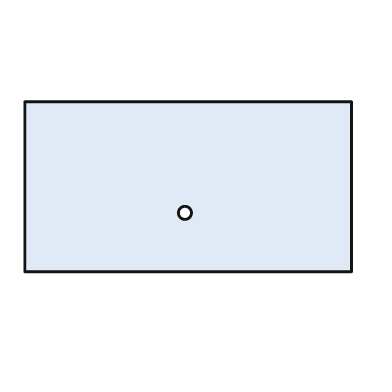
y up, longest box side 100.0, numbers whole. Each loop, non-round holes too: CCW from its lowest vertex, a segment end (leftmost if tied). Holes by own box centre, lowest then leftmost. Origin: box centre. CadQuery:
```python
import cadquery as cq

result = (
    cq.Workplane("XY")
    .moveTo(-50.0, -26.0)
    .lineTo(50.0, -26.0)
    .lineTo(50.0, 26.0)
    .lineTo(-50.0, 26.0)
    .close()
    .moveTo(-1.0, -8.0)
    .circle(2.0)
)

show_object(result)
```